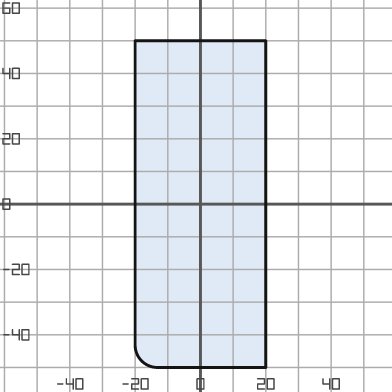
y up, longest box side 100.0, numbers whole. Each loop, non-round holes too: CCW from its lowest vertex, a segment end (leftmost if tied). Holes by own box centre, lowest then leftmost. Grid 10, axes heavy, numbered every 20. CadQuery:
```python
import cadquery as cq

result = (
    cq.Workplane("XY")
    .moveTo(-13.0, -50.0)
    .lineTo(20.0, -50.0)
    .lineTo(20.0, 50.0)
    .lineTo(-20.0, 50.0)
    .lineTo(-20.0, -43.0)
    .threePointArc((-18.0, -48.0), (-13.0, -50.0))
    .close()
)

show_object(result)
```